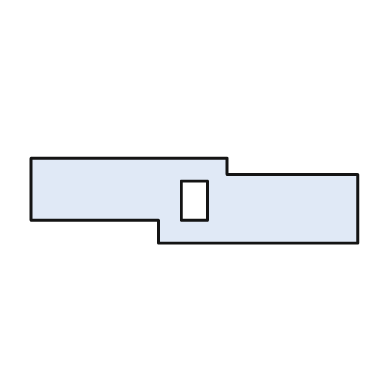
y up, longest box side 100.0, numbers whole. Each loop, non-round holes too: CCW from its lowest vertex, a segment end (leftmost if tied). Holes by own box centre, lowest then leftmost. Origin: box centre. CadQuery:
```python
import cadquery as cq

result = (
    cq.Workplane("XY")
    .moveTo(-11.0, -13.0)
    .lineTo(50.0, -13.0)
    .lineTo(50.0, 8.0)
    .lineTo(10.0, 8.0)
    .lineTo(10.0, 13.0)
    .lineTo(-50.0, 13.0)
    .lineTo(-50.0, -6.0)
    .lineTo(-11.0, -6.0)
    .close()
    .moveTo(-4.0, -6.0)
    .lineTo(4.0, -6.0)
    .lineTo(4.0, 6.0)
    .lineTo(-4.0, 6.0)
    .close()
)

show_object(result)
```